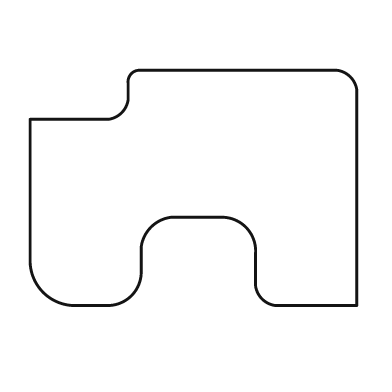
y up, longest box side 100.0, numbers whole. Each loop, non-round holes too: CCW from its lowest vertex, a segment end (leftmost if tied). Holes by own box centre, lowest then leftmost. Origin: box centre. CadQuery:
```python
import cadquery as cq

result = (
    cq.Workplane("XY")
    .moveTo(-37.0, -36.0)
    .lineTo(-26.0, -36.0)
    .threePointArc((-19.0, -33.0), (-16.0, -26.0))
    .lineTo(-16.0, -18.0)
    .threePointArc((-13.0, -12.0), (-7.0, -9.0))
    .lineTo(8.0, -9.0)
    .threePointArc((16.0, -12.0), (19.0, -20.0))
    .lineTo(19.0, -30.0)
    .threePointArc((21.0, -34.0), (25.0, -36.0))
    .lineTo(50.0, -36.0)
    .lineTo(50.0, 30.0)
    .threePointArc((48.0, 34.0), (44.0, 36.0))
    .lineTo(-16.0, 36.0)
    .threePointArc((-19.0, 35.0), (-20.0, 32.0))
    .lineTo(-20.0, 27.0)
    .threePointArc((-22.0, 23.0), (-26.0, 21.0))
    .lineTo(-50.0, 21.0)
    .lineTo(-50.0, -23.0)
    .threePointArc((-46.0, -32.0), (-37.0, -36.0))
    .close()
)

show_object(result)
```